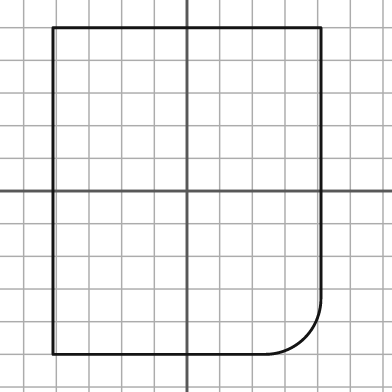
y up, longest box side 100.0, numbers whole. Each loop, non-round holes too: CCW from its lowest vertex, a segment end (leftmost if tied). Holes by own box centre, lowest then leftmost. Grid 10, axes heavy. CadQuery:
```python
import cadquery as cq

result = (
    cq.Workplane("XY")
    .moveTo(-41.0, -50.0)
    .lineTo(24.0, -50.0)
    .threePointArc((36.0, -45.0), (41.0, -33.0))
    .lineTo(41.0, 50.0)
    .lineTo(-41.0, 50.0)
    .close()
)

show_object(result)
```